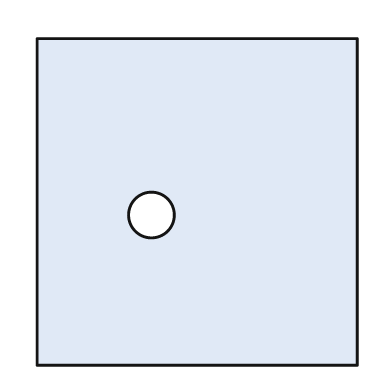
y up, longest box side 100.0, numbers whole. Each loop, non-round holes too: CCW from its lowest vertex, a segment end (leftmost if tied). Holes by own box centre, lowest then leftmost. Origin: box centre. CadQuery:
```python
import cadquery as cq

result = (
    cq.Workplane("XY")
    .moveTo(-49.0, -50.0)
    .lineTo(49.0, -50.0)
    .lineTo(49.0, 50.0)
    .lineTo(-49.0, 50.0)
    .close()
    .moveTo(-14.0, -4.0)
    .circle(7.0)
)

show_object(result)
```